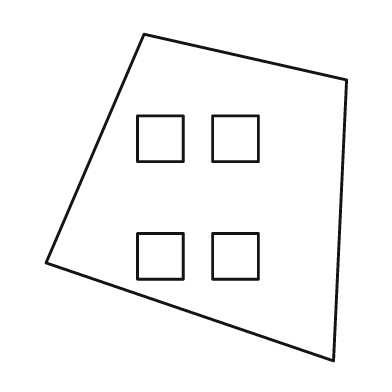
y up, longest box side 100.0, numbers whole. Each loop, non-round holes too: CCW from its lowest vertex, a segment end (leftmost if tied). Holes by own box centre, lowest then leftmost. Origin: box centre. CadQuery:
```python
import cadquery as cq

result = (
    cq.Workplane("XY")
    .moveTo(42.0, -50.0)
    .lineTo(46.0, 36.0)
    .lineTo(-16.0, 50.0)
    .lineTo(-46.0, -20.0)
    .close()
    .moveTo(-18.0, -25.0)
    .lineTo(-4.0, -25.0)
    .lineTo(-4.0, -11.0)
    .lineTo(-18.0, -11.0)
    .close()
    .moveTo(5.0, -25.0)
    .lineTo(19.0, -25.0)
    .lineTo(19.0, -11.0)
    .lineTo(5.0, -11.0)
    .close()
    .moveTo(-18.0, 11.0)
    .lineTo(-4.0, 11.0)
    .lineTo(-4.0, 25.0)
    .lineTo(-18.0, 25.0)
    .close()
    .moveTo(5.0, 11.0)
    .lineTo(19.0, 11.0)
    .lineTo(19.0, 25.0)
    .lineTo(5.0, 25.0)
    .close()
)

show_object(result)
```